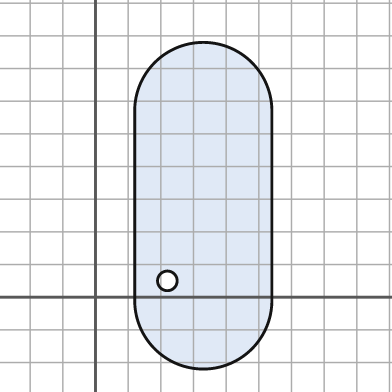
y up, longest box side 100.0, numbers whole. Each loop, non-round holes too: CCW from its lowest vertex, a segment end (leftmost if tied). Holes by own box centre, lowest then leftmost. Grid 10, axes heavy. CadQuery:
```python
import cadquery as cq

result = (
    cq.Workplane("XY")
    .moveTo(12.0, -1.0)
    .threePointArc((33.0, -22.0), (54.0, -1.0))
    .lineTo(54.0, 57.0)
    .threePointArc((33.0, 78.0), (12.0, 57.0))
    .close()
    .moveTo(22.0, 5.0)
    .circle(3.0)
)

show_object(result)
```